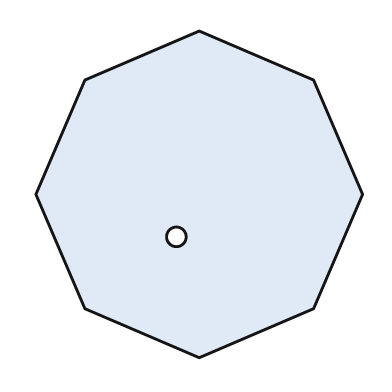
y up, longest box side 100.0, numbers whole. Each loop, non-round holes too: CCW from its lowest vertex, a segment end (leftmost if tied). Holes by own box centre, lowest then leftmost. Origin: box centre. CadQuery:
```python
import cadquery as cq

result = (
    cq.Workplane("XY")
    .moveTo(0.0, -50.0)
    .lineTo(35.0, -35.0)
    .lineTo(50.0, 0.0)
    .lineTo(35.0, 35.0)
    .lineTo(0.0, 50.0)
    .lineTo(-35.0, 35.0)
    .lineTo(-50.0, 0.0)
    .lineTo(-35.0, -35.0)
    .close()
    .moveTo(-7.0, -13.0)
    .circle(3.0)
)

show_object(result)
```